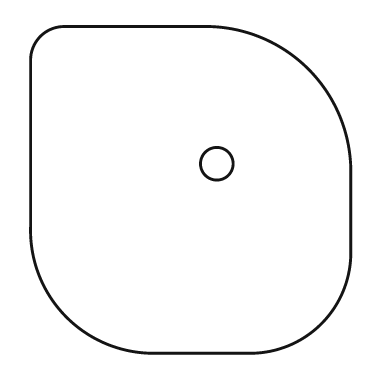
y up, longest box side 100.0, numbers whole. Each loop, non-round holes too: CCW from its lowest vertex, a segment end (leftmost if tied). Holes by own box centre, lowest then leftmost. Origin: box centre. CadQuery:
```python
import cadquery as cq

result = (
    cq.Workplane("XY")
    .moveTo(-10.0, -50.0)
    .lineTo(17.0, -50.0)
    .threePointArc((40.0, -41.0), (49.0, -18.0))
    .lineTo(49.0, 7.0)
    .threePointArc((36.0, 37.0), (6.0, 50.0))
    .lineTo(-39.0, 50.0)
    .threePointArc((-46.0, 47.0), (-49.0, 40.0))
    .lineTo(-49.0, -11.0)
    .threePointArc((-38.0, -39.0), (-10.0, -50.0))
    .close()
    .moveTo(8.0, 8.0)
    .circle(5.0)
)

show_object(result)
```